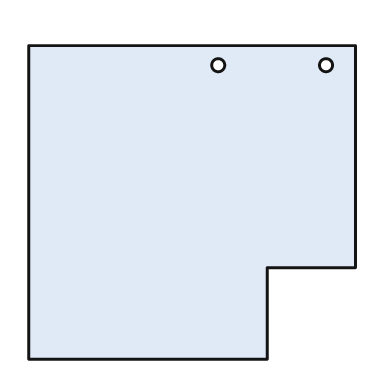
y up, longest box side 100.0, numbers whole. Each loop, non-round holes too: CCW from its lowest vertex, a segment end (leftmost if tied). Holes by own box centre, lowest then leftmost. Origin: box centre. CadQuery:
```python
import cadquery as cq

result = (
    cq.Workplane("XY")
    .moveTo(-50.0, -48.0)
    .lineTo(23.0, -48.0)
    .lineTo(23.0, -20.0)
    .lineTo(50.0, -20.0)
    .lineTo(50.0, 48.0)
    .lineTo(-50.0, 48.0)
    .close()
    .moveTo(8.0, 42.0)
    .circle(2.0)
    .moveTo(41.0, 42.0)
    .circle(2.0)
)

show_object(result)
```